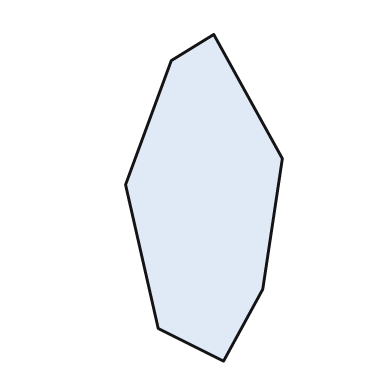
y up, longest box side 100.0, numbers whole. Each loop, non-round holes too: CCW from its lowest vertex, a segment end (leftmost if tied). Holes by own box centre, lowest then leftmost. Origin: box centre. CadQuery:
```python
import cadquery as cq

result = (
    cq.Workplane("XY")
    .moveTo(6.0, -50.0)
    .lineTo(18.0, -28.0)
    .lineTo(24.0, 12.0)
    .lineTo(3.0, 50.0)
    .lineTo(-10.0, 42.0)
    .lineTo(-24.0, 4.0)
    .lineTo(-14.0, -40.0)
    .close()
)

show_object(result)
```